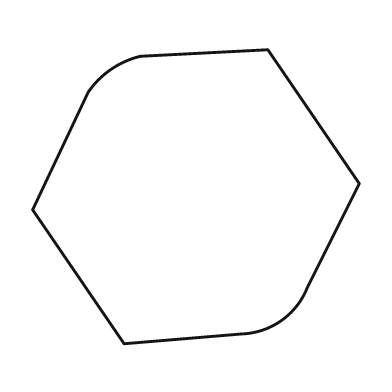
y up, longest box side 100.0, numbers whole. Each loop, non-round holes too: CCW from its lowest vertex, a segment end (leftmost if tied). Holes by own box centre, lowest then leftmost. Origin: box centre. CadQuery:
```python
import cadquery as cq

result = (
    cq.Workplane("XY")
    .moveTo(-22.0, -45.0)
    .lineTo(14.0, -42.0)
    .threePointArc((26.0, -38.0), (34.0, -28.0))
    .lineTo(50.0, 4.0)
    .lineTo(22.0, 45.0)
    .lineTo(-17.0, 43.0)
    .threePointArc((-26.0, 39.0), (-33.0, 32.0))
    .lineTo(-50.0, -4.0)
    .close()
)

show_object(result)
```